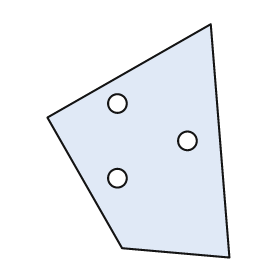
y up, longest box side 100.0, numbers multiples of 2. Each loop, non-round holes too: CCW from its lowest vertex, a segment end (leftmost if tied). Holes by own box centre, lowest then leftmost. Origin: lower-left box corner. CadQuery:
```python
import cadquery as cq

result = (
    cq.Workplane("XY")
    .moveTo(78.0, 0.0)
    .lineTo(70.0, 100.0)
    .lineTo(0.0, 60.0)
    .lineTo(32.0, 4.0)
    .close()
    .moveTo(30.0, 34.0)
    .circle(4.0)
    .moveTo(60.0, 50.0)
    .circle(4.0)
    .moveTo(30.0, 66.0)
    .circle(4.0)
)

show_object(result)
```